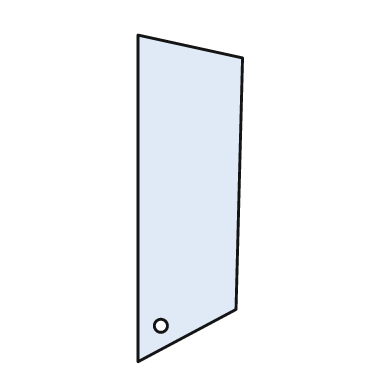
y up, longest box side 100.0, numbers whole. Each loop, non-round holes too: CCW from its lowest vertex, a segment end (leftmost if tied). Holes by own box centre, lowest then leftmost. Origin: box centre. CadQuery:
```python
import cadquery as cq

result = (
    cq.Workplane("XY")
    .moveTo(-16.0, -50.0)
    .lineTo(14.0, -34.0)
    .lineTo(16.0, 43.0)
    .lineTo(-16.0, 50.0)
    .close()
    .moveTo(-9.0, -39.0)
    .circle(2.0)
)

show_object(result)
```